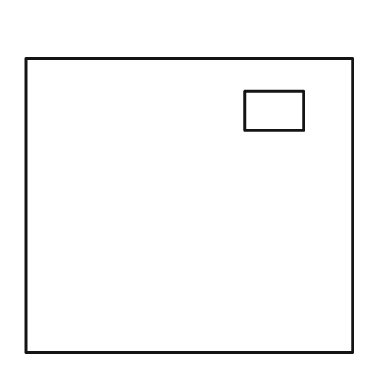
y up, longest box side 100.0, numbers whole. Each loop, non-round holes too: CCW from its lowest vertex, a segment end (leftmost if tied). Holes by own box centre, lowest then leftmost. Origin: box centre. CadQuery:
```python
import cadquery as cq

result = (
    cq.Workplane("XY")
    .moveTo(-50.0, -45.0)
    .lineTo(50.0, -45.0)
    .lineTo(50.0, 45.0)
    .lineTo(-50.0, 45.0)
    .close()
    .moveTo(17.0, 23.0)
    .lineTo(35.0, 23.0)
    .lineTo(35.0, 35.0)
    .lineTo(17.0, 35.0)
    .close()
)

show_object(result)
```